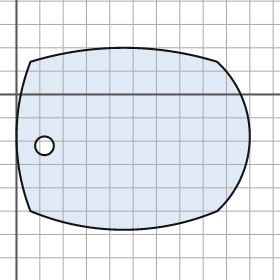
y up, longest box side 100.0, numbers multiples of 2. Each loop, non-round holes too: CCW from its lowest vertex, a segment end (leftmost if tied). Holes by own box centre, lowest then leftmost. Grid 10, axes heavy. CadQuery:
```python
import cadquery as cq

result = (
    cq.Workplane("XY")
    .moveTo(6.0, -50.0)
    .threePointArc((46.0, -58.0), (86.0, -50.0))
    .threePointArc((100.0, -18.0), (86.0, 14.0))
    .threePointArc((46.0, 20.0), (6.0, 14.0))
    .threePointArc((0.0, -18.0), (6.0, -50.0))
    .close()
    .moveTo(12.0, -22.0)
    .circle(4.0)
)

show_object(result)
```